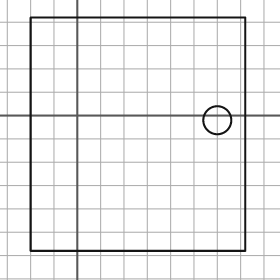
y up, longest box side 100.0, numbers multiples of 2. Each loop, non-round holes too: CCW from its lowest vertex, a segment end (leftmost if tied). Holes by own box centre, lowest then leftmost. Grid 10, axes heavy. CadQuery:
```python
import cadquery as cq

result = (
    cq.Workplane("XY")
    .moveTo(-20.0, -58.0)
    .lineTo(72.0, -58.0)
    .lineTo(72.0, 42.0)
    .lineTo(-20.0, 42.0)
    .close()
    .moveTo(60.0, -2.0)
    .circle(6.0)
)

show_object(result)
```